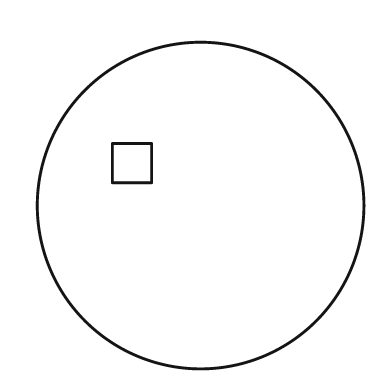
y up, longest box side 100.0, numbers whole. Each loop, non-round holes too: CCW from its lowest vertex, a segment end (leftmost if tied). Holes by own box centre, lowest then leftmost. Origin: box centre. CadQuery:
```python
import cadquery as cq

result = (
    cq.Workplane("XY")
    .moveTo(0.0, 0.0)
    .circle(50.0)
    .moveTo(-27.0, 7.0)
    .lineTo(-15.0, 7.0)
    .lineTo(-15.0, 19.0)
    .lineTo(-27.0, 19.0)
    .close()
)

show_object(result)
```